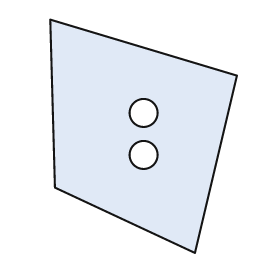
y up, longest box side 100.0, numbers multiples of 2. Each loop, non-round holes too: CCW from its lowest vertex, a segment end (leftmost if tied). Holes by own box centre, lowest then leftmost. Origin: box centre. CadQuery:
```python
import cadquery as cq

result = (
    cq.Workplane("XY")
    .moveTo(22.0, -50.0)
    .lineTo(40.0, 26.0)
    .lineTo(-40.0, 50.0)
    .lineTo(-38.0, -22.0)
    .close()
    .moveTo(0.0, -8.0)
    .circle(6.0)
    .moveTo(0.0, 10.0)
    .circle(6.0)
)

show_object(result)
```